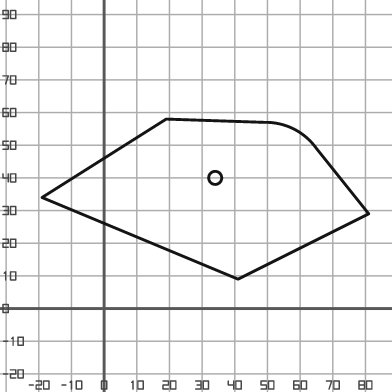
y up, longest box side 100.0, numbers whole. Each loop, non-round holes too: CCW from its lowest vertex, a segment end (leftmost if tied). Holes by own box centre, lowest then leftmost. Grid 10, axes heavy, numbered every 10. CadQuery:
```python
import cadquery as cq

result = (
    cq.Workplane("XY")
    .moveTo(41.0, 9.0)
    .lineTo(81.0, 29.0)
    .lineTo(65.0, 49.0)
    .threePointArc((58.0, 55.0), (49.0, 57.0))
    .lineTo(19.0, 58.0)
    .lineTo(-19.0, 34.0)
    .close()
    .moveTo(34.0, 40.0)
    .circle(2.0)
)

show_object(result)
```